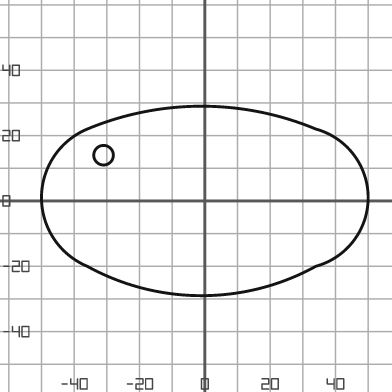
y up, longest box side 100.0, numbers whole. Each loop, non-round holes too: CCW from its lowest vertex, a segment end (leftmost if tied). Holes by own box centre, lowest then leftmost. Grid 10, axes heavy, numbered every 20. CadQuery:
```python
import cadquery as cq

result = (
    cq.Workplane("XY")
    .moveTo(-36.0, -20.0)
    .threePointArc((-1.0, -29.0), (34.0, -20.0))
    .threePointArc((50.0, 1.0), (34.0, 22.0))
    .threePointArc((-1.0, 29.0), (-36.0, 22.0))
    .threePointArc((-50.0, 1.0), (-36.0, -20.0))
    .close()
    .moveTo(-31.0, 14.0)
    .circle(3.0)
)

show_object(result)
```